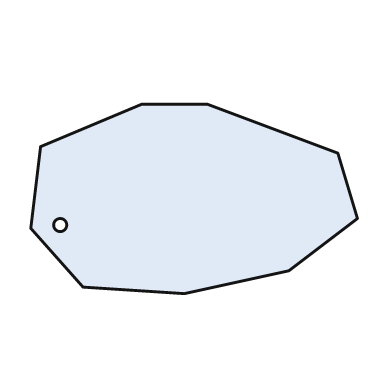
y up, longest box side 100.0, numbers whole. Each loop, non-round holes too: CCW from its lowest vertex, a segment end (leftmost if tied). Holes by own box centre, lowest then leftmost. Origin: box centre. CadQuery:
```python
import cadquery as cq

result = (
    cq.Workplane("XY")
    .moveTo(-3.0, -29.0)
    .lineTo(29.0, -22.0)
    .lineTo(50.0, -6.0)
    .lineTo(44.0, 14.0)
    .lineTo(4.0, 29.0)
    .lineTo(-16.0, 29.0)
    .lineTo(-47.0, 16.0)
    .lineTo(-50.0, -9.0)
    .lineTo(-34.0, -27.0)
    .close()
    .moveTo(-41.0, -8.0)
    .circle(2.0)
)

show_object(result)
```